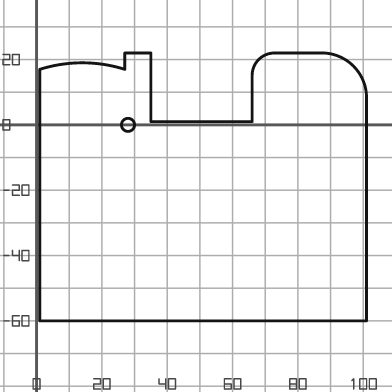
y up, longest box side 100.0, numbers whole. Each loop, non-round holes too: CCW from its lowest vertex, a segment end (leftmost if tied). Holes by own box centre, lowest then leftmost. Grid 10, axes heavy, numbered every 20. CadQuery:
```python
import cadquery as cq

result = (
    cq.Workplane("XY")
    .moveTo(1.0, -60.0)
    .lineTo(101.0, -60.0)
    .lineTo(101.0, 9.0)
    .threePointArc((97.0, 18.0), (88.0, 22.0))
    .lineTo(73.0, 22.0)
    .threePointArc((68.0, 20.0), (66.0, 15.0))
    .lineTo(66.0, 1.0)
    .lineTo(35.0, 1.0)
    .lineTo(35.0, 22.0)
    .lineTo(27.0, 22.0)
    .lineTo(27.0, 17.0)
    .threePointArc((14.0, 19.0), (1.0, 17.0))
    .close()
    .moveTo(28.0, 0.0)
    .circle(2.0)
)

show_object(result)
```